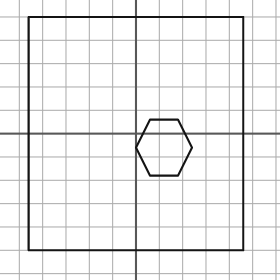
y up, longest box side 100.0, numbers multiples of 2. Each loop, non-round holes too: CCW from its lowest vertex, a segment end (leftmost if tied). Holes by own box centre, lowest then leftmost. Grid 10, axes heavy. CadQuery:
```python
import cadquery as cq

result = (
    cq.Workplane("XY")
    .moveTo(-46.0, -50.0)
    .lineTo(46.0, -50.0)
    .lineTo(46.0, 50.0)
    .lineTo(-46.0, 50.0)
    .close()
    .moveTo(6.0, -18.0)
    .lineTo(18.0, -18.0)
    .lineTo(24.0, -6.0)
    .lineTo(18.0, 6.0)
    .lineTo(6.0, 6.0)
    .lineTo(0.0, -6.0)
    .close()
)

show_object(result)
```